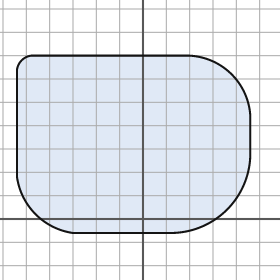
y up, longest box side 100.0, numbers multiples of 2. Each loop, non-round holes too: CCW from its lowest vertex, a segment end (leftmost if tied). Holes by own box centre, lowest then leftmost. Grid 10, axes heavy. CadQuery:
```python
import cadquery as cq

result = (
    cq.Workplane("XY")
    .moveTo(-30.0, -6.0)
    .lineTo(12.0, -6.0)
    .threePointArc((36.0, 4.0), (46.0, 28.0))
    .lineTo(46.0, 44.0)
    .threePointArc((38.0, 62.0), (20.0, 70.0))
    .lineTo(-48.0, 70.0)
    .threePointArc((-52.0, 68.0), (-54.0, 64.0))
    .lineTo(-54.0, 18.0)
    .threePointArc((-46.0, 2.0), (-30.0, -6.0))
    .close()
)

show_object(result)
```